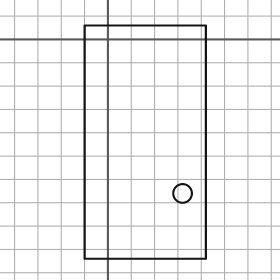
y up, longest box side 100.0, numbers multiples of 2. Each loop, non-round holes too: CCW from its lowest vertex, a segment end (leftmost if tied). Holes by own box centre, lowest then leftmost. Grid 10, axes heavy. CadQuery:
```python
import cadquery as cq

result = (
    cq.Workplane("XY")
    .moveTo(-10.0, -94.0)
    .lineTo(42.0, -94.0)
    .lineTo(42.0, 6.0)
    .lineTo(-10.0, 6.0)
    .close()
    .moveTo(32.0, -66.0)
    .circle(4.0)
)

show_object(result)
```